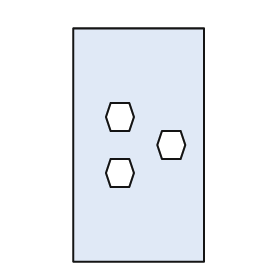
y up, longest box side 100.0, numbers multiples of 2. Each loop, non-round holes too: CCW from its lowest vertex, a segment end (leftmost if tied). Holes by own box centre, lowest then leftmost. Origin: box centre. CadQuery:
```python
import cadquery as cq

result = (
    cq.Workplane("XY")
    .moveTo(-28.0, -50.0)
    .lineTo(28.0, -50.0)
    .lineTo(28.0, 50.0)
    .lineTo(-28.0, 50.0)
    .close()
    .moveTo(-12.0, -18.0)
    .lineTo(-4.0, -18.0)
    .lineTo(-2.0, -12.0)
    .lineTo(-4.0, -6.0)
    .lineTo(-12.0, -6.0)
    .lineTo(-14.0, -12.0)
    .close()
    .moveTo(10.0, -6.0)
    .lineTo(18.0, -6.0)
    .lineTo(20.0, 0.0)
    .lineTo(18.0, 6.0)
    .lineTo(10.0, 6.0)
    .lineTo(8.0, 0.0)
    .close()
    .moveTo(-12.0, 6.0)
    .lineTo(-4.0, 6.0)
    .lineTo(-2.0, 12.0)
    .lineTo(-4.0, 18.0)
    .lineTo(-12.0, 18.0)
    .lineTo(-14.0, 12.0)
    .close()
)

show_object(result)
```